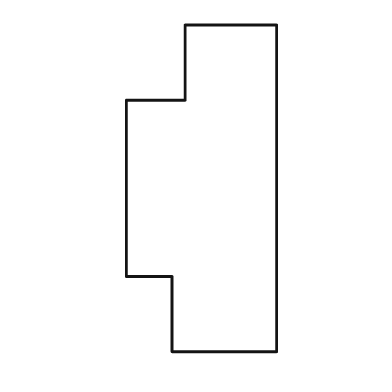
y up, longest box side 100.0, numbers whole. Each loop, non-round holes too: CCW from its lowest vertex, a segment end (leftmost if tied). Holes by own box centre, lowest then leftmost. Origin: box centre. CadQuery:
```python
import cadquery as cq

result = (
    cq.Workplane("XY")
    .moveTo(-9.0, -50.0)
    .lineTo(23.0, -50.0)
    .lineTo(23.0, 50.0)
    .lineTo(-5.0, 50.0)
    .lineTo(-5.0, 27.0)
    .lineTo(-23.0, 27.0)
    .lineTo(-23.0, -27.0)
    .lineTo(-9.0, -27.0)
    .close()
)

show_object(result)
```